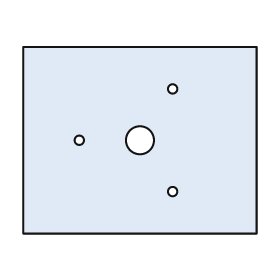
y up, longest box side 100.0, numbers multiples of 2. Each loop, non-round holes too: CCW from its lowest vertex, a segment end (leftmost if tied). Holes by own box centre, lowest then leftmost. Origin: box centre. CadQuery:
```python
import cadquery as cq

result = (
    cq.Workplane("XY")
    .moveTo(-50.0, -40.0)
    .lineTo(50.0, -40.0)
    .lineTo(50.0, 40.0)
    .lineTo(-50.0, 40.0)
    .close()
    .moveTo(14.0, -22.0)
    .circle(2.0)
    .moveTo(-26.0, 0.0)
    .circle(2.0)
    .moveTo(0.0, 0.0)
    .circle(6.0)
    .moveTo(14.0, 22.0)
    .circle(2.0)
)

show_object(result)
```